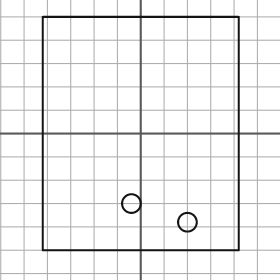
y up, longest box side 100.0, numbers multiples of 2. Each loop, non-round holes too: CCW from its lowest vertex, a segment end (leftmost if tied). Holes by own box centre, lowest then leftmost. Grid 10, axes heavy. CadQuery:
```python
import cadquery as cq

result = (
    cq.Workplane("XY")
    .moveTo(-42.0, -50.0)
    .lineTo(42.0, -50.0)
    .lineTo(42.0, 50.0)
    .lineTo(-42.0, 50.0)
    .close()
    .moveTo(20.0, -38.0)
    .circle(4.0)
    .moveTo(-4.0, -30.0)
    .circle(4.0)
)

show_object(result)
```